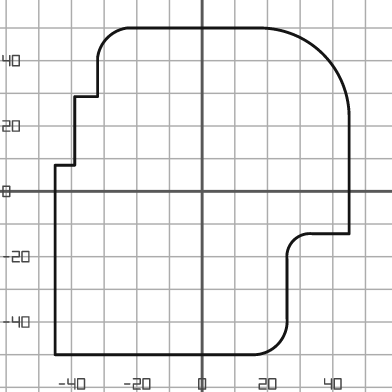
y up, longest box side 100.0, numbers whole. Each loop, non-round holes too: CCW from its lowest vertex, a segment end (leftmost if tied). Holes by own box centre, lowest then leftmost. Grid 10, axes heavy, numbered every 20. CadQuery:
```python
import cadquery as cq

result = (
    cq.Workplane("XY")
    .moveTo(-45.0, -50.0)
    .lineTo(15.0, -50.0)
    .threePointArc((23.0, -47.0), (26.0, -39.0))
    .lineTo(26.0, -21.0)
    .threePointArc((28.0, -15.0), (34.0, -13.0))
    .lineTo(45.0, -13.0)
    .lineTo(45.0, 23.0)
    .threePointArc((37.0, 42.0), (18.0, 50.0))
    .lineTo(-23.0, 50.0)
    .threePointArc((-29.0, 47.0), (-32.0, 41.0))
    .lineTo(-32.0, 29.0)
    .lineTo(-39.0, 29.0)
    .lineTo(-39.0, 8.0)
    .lineTo(-45.0, 8.0)
    .close()
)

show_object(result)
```